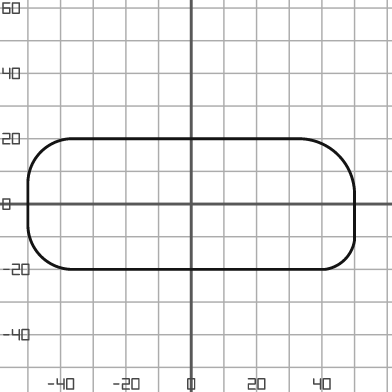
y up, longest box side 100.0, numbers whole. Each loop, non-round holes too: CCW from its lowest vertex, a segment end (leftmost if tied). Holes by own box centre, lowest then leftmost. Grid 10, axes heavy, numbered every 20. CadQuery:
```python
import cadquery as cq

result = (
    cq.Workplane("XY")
    .moveTo(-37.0, -20.0)
    .lineTo(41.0, -20.0)
    .threePointArc((47.0, -17.0), (50.0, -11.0))
    .lineTo(50.0, 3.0)
    .threePointArc((45.0, 15.0), (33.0, 20.0))
    .lineTo(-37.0, 20.0)
    .threePointArc((-46.0, 16.0), (-50.0, 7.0))
    .lineTo(-50.0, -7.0)
    .threePointArc((-46.0, -16.0), (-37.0, -20.0))
    .close()
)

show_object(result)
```